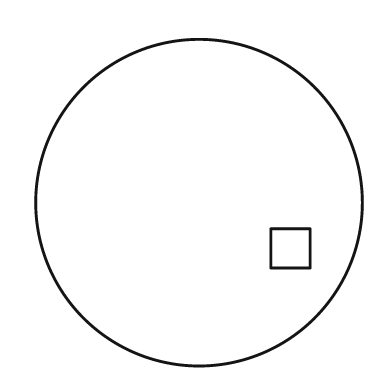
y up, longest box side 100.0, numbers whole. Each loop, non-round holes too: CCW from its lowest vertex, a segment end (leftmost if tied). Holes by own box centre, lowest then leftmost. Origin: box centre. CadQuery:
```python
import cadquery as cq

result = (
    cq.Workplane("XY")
    .moveTo(0.0, 0.0)
    .circle(50.0)
    .moveTo(22.0, -20.0)
    .lineTo(34.0, -20.0)
    .lineTo(34.0, -8.0)
    .lineTo(22.0, -8.0)
    .close()
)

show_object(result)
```